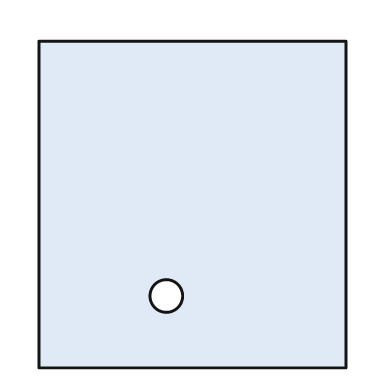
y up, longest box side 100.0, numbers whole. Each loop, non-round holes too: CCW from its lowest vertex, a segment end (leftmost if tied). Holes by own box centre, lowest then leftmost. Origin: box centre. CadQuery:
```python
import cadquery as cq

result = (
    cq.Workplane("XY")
    .moveTo(-47.0, -50.0)
    .lineTo(47.0, -50.0)
    .lineTo(47.0, 50.0)
    .lineTo(-47.0, 50.0)
    .close()
    .moveTo(-8.0, -28.0)
    .circle(5.0)
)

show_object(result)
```